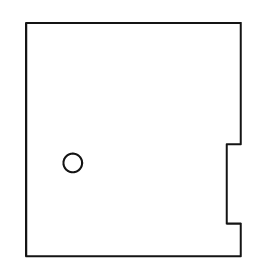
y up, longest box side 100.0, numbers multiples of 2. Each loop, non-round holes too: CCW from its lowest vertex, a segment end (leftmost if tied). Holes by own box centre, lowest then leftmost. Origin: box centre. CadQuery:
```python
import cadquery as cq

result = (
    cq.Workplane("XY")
    .moveTo(-46.0, -50.0)
    .lineTo(46.0, -50.0)
    .lineTo(46.0, -36.0)
    .lineTo(40.0, -36.0)
    .lineTo(40.0, -2.0)
    .lineTo(46.0, -2.0)
    .lineTo(46.0, 50.0)
    .lineTo(-46.0, 50.0)
    .close()
    .moveTo(-26.0, -10.0)
    .circle(4.0)
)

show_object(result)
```